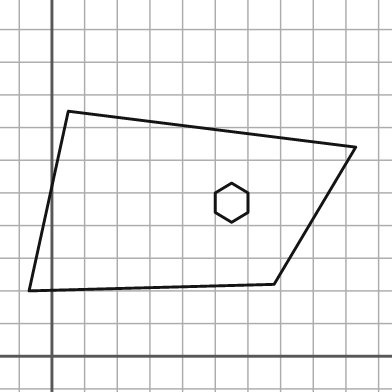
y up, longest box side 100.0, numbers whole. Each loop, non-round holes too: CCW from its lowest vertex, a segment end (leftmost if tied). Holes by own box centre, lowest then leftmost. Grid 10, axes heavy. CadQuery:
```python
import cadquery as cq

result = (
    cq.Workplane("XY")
    .moveTo(-7.0, 20.0)
    .lineTo(68.0, 22.0)
    .lineTo(93.0, 64.0)
    .lineTo(5.0, 75.0)
    .close()
    .moveTo(55.0, 41.0)
    .lineTo(60.0, 44.0)
    .lineTo(60.0, 50.0)
    .lineTo(55.0, 53.0)
    .lineTo(50.0, 50.0)
    .lineTo(50.0, 44.0)
    .close()
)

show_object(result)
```